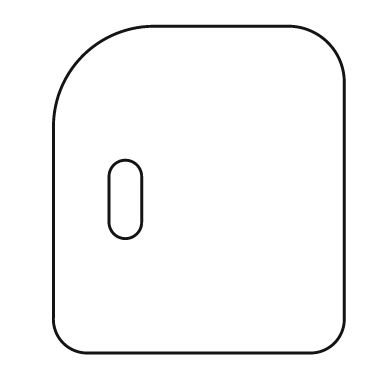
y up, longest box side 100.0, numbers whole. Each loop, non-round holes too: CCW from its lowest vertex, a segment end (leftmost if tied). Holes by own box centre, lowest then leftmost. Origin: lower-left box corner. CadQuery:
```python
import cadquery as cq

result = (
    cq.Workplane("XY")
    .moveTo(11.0, 0.0)
    .lineTo(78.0, 0.0)
    .threePointArc((86.0, 3.0), (89.0, 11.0))
    .lineTo(89.0, 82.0)
    .threePointArc((84.0, 95.0), (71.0, 100.0))
    .lineTo(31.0, 100.0)
    .threePointArc((9.0, 91.0), (0.0, 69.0))
    .lineTo(0.0, 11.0)
    .threePointArc((3.0, 3.0), (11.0, 0.0))
    .close()
    .moveTo(17.0, 40.0)
    .threePointArc((22.0, 35.0), (27.0, 40.0))
    .lineTo(27.0, 54.0)
    .threePointArc((22.0, 59.0), (17.0, 54.0))
    .close()
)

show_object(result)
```